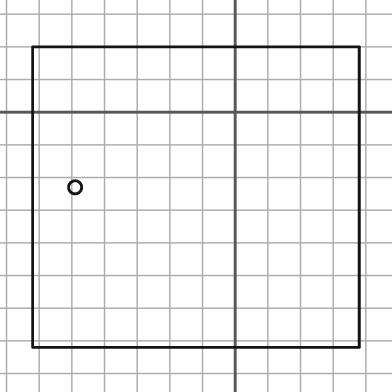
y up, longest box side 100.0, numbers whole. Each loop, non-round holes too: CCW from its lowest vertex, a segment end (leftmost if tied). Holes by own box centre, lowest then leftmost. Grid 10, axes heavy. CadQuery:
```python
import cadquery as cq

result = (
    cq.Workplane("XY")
    .moveTo(-62.0, -72.0)
    .lineTo(38.0, -72.0)
    .lineTo(38.0, 20.0)
    .lineTo(-62.0, 20.0)
    .close()
    .moveTo(-49.0, -23.0)
    .circle(2.0)
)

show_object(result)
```